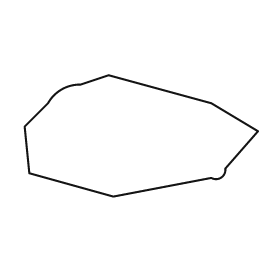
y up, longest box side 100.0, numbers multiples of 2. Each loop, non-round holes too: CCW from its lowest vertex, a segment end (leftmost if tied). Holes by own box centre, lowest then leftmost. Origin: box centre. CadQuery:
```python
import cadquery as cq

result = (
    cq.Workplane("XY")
    .moveTo(-12.0, -26.0)
    .lineTo(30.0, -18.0)
    .threePointArc((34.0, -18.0), (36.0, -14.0))
    .lineTo(50.0, 2.0)
    .lineTo(30.0, 14.0)
    .lineTo(-14.0, 26.0)
    .lineTo(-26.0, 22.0)
    .threePointArc((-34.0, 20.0), (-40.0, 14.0))
    .lineTo(-50.0, 4.0)
    .lineTo(-48.0, -16.0)
    .close()
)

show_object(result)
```